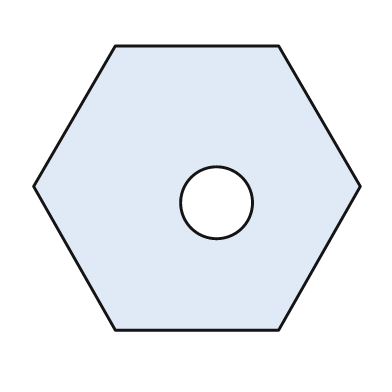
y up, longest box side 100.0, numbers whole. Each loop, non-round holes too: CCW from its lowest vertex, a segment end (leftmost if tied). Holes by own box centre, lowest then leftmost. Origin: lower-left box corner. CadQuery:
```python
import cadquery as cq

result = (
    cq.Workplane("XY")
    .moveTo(25.0, 0.0)
    .lineTo(75.0, 0.0)
    .lineTo(100.0, 44.0)
    .lineTo(75.0, 87.0)
    .lineTo(25.0, 87.0)
    .lineTo(0.0, 44.0)
    .close()
    .moveTo(56.0, 39.0)
    .circle(11.0)
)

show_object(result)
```